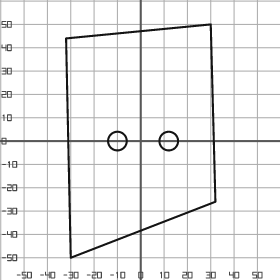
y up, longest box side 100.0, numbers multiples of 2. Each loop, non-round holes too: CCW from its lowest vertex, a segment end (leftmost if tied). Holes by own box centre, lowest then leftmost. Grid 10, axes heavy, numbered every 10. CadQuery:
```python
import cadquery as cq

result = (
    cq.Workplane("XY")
    .moveTo(-30.0, -50.0)
    .lineTo(32.0, -26.0)
    .lineTo(30.0, 50.0)
    .lineTo(-32.0, 44.0)
    .close()
    .moveTo(-10.0, 0.0)
    .circle(4.0)
    .moveTo(12.0, 0.0)
    .circle(4.0)
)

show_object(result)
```